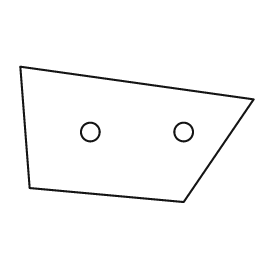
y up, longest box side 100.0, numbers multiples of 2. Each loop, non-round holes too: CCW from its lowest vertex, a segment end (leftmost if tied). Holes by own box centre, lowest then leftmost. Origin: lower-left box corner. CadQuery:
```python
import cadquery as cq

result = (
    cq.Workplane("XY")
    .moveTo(70.0, 0.0)
    .lineTo(100.0, 44.0)
    .lineTo(0.0, 58.0)
    .lineTo(4.0, 6.0)
    .close()
    .moveTo(30.0, 30.0)
    .circle(4.0)
    .moveTo(70.0, 30.0)
    .circle(4.0)
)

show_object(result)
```